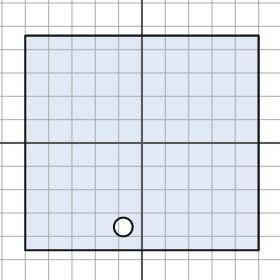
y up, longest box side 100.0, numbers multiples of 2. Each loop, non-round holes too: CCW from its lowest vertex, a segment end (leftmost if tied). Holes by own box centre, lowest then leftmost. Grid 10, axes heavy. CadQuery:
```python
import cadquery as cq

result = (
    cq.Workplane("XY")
    .moveTo(-50.0, -46.0)
    .lineTo(50.0, -46.0)
    .lineTo(50.0, 46.0)
    .lineTo(-50.0, 46.0)
    .close()
    .moveTo(-8.0, -36.0)
    .circle(4.0)
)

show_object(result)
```